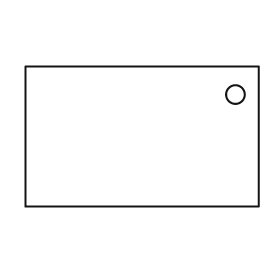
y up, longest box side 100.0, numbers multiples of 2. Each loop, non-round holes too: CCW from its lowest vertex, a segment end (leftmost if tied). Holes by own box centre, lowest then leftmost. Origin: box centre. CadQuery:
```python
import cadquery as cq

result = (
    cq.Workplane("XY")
    .moveTo(-50.0, -30.0)
    .lineTo(50.0, -30.0)
    .lineTo(50.0, 30.0)
    .lineTo(-50.0, 30.0)
    .close()
    .moveTo(40.0, 18.0)
    .circle(4.0)
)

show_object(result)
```